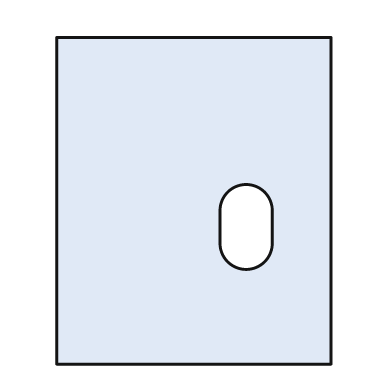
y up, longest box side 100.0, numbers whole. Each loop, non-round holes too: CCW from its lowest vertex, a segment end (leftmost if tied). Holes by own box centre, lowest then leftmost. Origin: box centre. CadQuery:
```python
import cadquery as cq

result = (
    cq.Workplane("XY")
    .moveTo(-42.0, -50.0)
    .lineTo(42.0, -50.0)
    .lineTo(42.0, 50.0)
    .lineTo(-42.0, 50.0)
    .close()
    .moveTo(8.0, -13.0)
    .threePointArc((16.0, -21.0), (24.0, -13.0))
    .lineTo(24.0, -3.0)
    .threePointArc((16.0, 5.0), (8.0, -3.0))
    .close()
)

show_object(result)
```